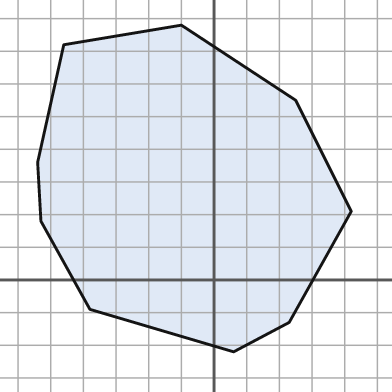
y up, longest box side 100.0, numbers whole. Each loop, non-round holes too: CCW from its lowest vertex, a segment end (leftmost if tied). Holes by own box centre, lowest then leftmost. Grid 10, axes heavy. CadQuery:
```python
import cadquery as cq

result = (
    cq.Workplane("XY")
    .moveTo(6.0, -22.0)
    .lineTo(23.0, -13.0)
    .lineTo(42.0, 21.0)
    .lineTo(25.0, 55.0)
    .lineTo(-10.0, 78.0)
    .lineTo(-46.0, 72.0)
    .lineTo(-54.0, 36.0)
    .lineTo(-53.0, 18.0)
    .lineTo(-38.0, -9.0)
    .close()
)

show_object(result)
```